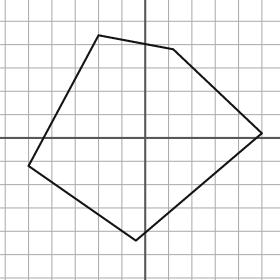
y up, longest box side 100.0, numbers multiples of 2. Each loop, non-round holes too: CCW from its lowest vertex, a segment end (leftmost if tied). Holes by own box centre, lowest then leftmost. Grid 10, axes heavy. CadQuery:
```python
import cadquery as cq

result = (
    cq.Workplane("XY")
    .moveTo(-4.0, -44.0)
    .lineTo(50.0, 2.0)
    .lineTo(12.0, 38.0)
    .lineTo(-20.0, 44.0)
    .lineTo(-50.0, -12.0)
    .close()
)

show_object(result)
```